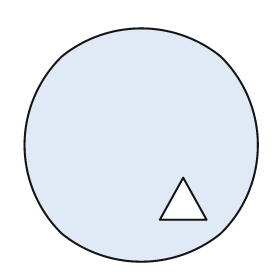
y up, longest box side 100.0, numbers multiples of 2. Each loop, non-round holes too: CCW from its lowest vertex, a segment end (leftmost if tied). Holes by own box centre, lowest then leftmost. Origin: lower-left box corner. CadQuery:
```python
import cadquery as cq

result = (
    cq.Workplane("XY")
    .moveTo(16.0, 12.0)
    .threePointArc((50.0, 0.0), (84.0, 12.0))
    .threePointArc((100.0, 50.0), (84.0, 88.0))
    .threePointArc((50.0, 100.0), (16.0, 88.0))
    .threePointArc((0.0, 50.0), (16.0, 12.0))
    .close()
    .moveTo(58.0, 18.0)
    .lineTo(78.0, 18.0)
    .lineTo(68.0, 36.0)
    .close()
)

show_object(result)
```